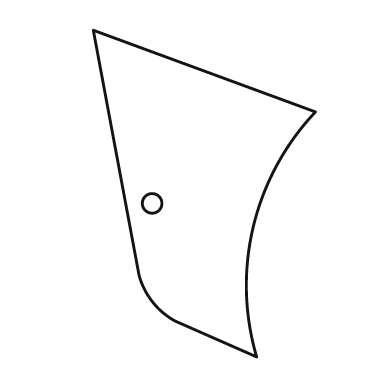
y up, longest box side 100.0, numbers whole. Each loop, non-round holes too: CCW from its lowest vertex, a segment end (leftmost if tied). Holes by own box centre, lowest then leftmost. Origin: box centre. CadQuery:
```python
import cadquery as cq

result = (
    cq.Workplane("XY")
    .moveTo(16.0, -50.0)
    .threePointArc((15.0, -10.0), (34.0, 25.0))
    .lineTo(-34.0, 50.0)
    .lineTo(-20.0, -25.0)
    .threePointArc((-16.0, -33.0), (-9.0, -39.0))
    .close()
    .moveTo(-16.0, -3.0)
    .circle(3.0)
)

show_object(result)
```